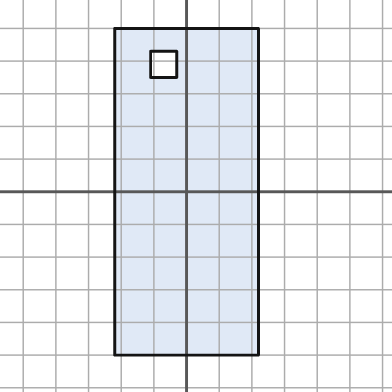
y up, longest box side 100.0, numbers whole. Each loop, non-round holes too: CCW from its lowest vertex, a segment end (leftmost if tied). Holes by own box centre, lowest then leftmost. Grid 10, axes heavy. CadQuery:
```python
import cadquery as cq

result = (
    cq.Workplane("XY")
    .moveTo(-22.0, -50.0)
    .lineTo(22.0, -50.0)
    .lineTo(22.0, 50.0)
    .lineTo(-22.0, 50.0)
    .close()
    .moveTo(-11.0, 35.0)
    .lineTo(-3.0, 35.0)
    .lineTo(-3.0, 43.0)
    .lineTo(-11.0, 43.0)
    .close()
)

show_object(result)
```